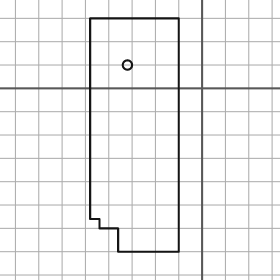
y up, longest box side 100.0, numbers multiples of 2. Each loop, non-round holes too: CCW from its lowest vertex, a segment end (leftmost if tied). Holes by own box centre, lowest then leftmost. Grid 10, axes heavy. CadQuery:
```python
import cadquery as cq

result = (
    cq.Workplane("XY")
    .moveTo(-36.0, -70.0)
    .lineTo(-10.0, -70.0)
    .lineTo(-10.0, 30.0)
    .lineTo(-48.0, 30.0)
    .lineTo(-48.0, -56.0)
    .lineTo(-44.0, -56.0)
    .lineTo(-44.0, -60.0)
    .lineTo(-36.0, -60.0)
    .close()
    .moveTo(-32.0, 10.0)
    .circle(2.0)
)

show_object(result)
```